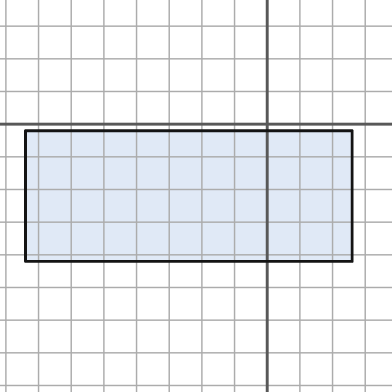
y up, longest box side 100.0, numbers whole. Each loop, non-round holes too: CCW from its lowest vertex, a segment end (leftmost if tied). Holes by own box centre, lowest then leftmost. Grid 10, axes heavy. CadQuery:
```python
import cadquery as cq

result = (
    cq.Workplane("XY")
    .moveTo(-74.0, -42.0)
    .lineTo(26.0, -42.0)
    .lineTo(26.0, -2.0)
    .lineTo(-74.0, -2.0)
    .close()
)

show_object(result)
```